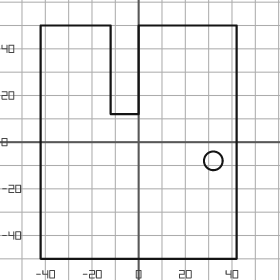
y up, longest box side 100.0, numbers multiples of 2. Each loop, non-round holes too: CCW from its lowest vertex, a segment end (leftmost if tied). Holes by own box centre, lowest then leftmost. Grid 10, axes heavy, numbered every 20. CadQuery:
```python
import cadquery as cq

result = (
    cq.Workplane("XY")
    .moveTo(-42.0, -50.0)
    .lineTo(42.0, -50.0)
    .lineTo(42.0, 50.0)
    .lineTo(0.0, 50.0)
    .lineTo(0.0, 12.0)
    .lineTo(-12.0, 12.0)
    .lineTo(-12.0, 50.0)
    .lineTo(-42.0, 50.0)
    .close()
    .moveTo(32.0, -8.0)
    .circle(4.0)
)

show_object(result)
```